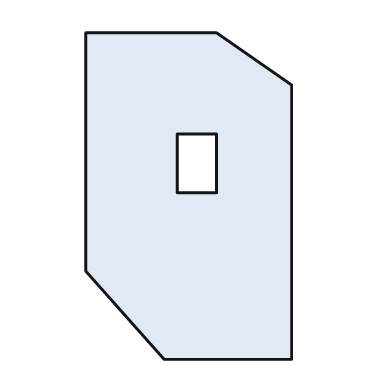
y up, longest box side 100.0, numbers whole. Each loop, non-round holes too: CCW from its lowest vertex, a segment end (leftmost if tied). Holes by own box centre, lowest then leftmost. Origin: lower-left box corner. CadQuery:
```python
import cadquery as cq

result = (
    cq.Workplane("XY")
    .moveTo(24.0, 0.0)
    .lineTo(63.0, 0.0)
    .lineTo(63.0, 84.0)
    .lineTo(40.0, 100.0)
    .lineTo(0.0, 100.0)
    .lineTo(0.0, 27.0)
    .close()
    .moveTo(28.0, 51.0)
    .lineTo(40.0, 51.0)
    .lineTo(40.0, 69.0)
    .lineTo(28.0, 69.0)
    .close()
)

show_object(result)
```